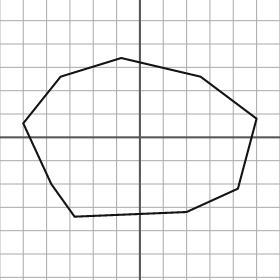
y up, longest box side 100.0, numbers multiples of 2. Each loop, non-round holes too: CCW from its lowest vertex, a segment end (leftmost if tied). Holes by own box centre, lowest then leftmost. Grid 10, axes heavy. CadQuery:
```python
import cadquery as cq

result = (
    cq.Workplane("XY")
    .moveTo(-28.0, -34.0)
    .lineTo(20.0, -32.0)
    .lineTo(42.0, -22.0)
    .lineTo(50.0, 8.0)
    .lineTo(26.0, 26.0)
    .lineTo(-8.0, 34.0)
    .lineTo(-34.0, 26.0)
    .lineTo(-50.0, 6.0)
    .lineTo(-38.0, -20.0)
    .close()
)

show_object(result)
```